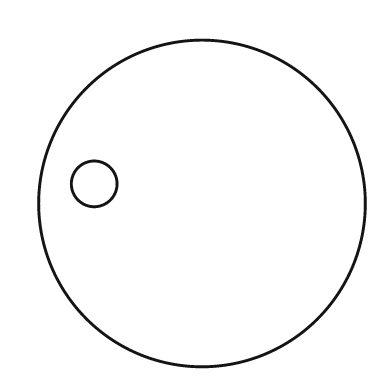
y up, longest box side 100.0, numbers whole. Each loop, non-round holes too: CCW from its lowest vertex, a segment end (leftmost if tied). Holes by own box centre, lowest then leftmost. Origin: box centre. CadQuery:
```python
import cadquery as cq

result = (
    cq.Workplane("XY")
    .moveTo(0.0, 0.0)
    .circle(50.0)
    .moveTo(-33.0, 6.0)
    .circle(7.0)
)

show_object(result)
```